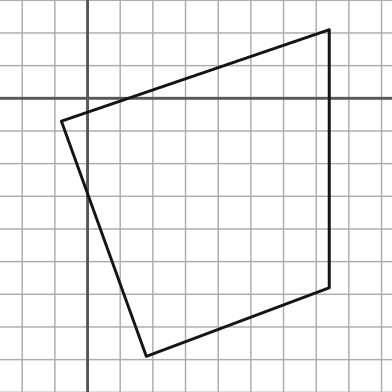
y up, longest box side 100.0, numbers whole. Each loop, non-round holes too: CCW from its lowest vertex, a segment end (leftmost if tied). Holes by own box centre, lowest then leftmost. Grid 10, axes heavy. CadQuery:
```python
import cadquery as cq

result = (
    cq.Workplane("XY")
    .moveTo(18.0, -79.0)
    .lineTo(74.0, -58.0)
    .lineTo(74.0, 21.0)
    .lineTo(-8.0, -7.0)
    .close()
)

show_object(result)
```